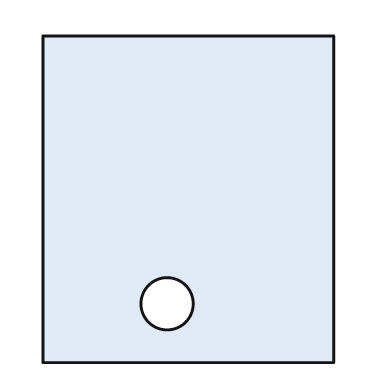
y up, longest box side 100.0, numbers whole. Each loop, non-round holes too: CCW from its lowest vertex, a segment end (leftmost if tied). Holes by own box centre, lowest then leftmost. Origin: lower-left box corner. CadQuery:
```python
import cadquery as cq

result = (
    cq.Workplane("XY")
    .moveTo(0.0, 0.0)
    .lineTo(89.0, 0.0)
    .lineTo(89.0, 100.0)
    .lineTo(0.0, 100.0)
    .close()
    .moveTo(38.0, 18.0)
    .circle(8.0)
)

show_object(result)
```